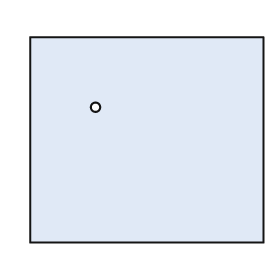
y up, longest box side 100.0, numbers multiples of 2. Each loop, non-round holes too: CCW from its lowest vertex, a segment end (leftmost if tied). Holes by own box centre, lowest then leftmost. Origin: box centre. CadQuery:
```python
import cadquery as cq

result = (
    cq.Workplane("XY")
    .moveTo(-50.0, -44.0)
    .lineTo(50.0, -44.0)
    .lineTo(50.0, 44.0)
    .lineTo(-50.0, 44.0)
    .close()
    .moveTo(-22.0, 14.0)
    .circle(2.0)
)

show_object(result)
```